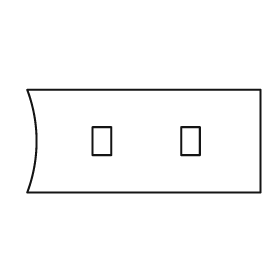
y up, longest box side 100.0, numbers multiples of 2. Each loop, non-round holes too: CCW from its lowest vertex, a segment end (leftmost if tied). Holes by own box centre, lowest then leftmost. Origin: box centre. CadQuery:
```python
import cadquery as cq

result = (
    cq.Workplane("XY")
    .moveTo(-50.0, -22.0)
    .lineTo(50.0, -22.0)
    .lineTo(50.0, 22.0)
    .lineTo(-50.0, 22.0)
    .threePointArc((-46.0, 0.0), (-50.0, -22.0))
    .close()
    .moveTo(-22.0, -6.0)
    .lineTo(-14.0, -6.0)
    .lineTo(-14.0, 6.0)
    .lineTo(-22.0, 6.0)
    .close()
    .moveTo(16.0, -6.0)
    .lineTo(24.0, -6.0)
    .lineTo(24.0, 6.0)
    .lineTo(16.0, 6.0)
    .close()
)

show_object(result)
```